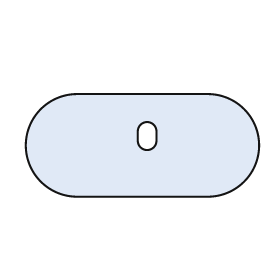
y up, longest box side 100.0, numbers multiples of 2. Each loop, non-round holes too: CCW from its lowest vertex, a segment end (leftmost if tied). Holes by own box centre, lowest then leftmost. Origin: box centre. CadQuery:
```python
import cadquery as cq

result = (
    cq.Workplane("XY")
    .moveTo(-28.0, -22.0)
    .lineTo(28.0, -22.0)
    .threePointArc((50.0, 0.0), (28.0, 22.0))
    .lineTo(-28.0, 22.0)
    .threePointArc((-50.0, 0.0), (-28.0, -22.0))
    .close()
    .moveTo(-2.0, 2.0)
    .threePointArc((2.0, -2.0), (6.0, 2.0))
    .lineTo(6.0, 6.0)
    .threePointArc((2.0, 10.0), (-2.0, 6.0))
    .close()
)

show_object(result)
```